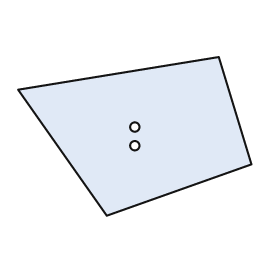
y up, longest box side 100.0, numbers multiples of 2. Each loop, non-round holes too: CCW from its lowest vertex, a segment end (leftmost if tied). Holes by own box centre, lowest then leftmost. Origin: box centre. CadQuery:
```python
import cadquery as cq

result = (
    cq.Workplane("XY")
    .moveTo(-12.0, -34.0)
    .lineTo(50.0, -12.0)
    .lineTo(36.0, 34.0)
    .lineTo(-50.0, 20.0)
    .close()
    .moveTo(0.0, -4.0)
    .circle(2.0)
    .moveTo(0.0, 4.0)
    .circle(2.0)
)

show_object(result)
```